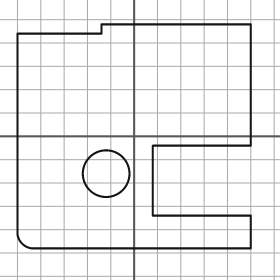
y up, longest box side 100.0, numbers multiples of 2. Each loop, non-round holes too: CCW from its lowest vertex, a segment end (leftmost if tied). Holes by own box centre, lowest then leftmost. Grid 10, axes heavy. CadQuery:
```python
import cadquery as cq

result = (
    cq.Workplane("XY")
    .moveTo(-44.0, -48.0)
    .lineTo(50.0, -48.0)
    .lineTo(50.0, -34.0)
    .lineTo(8.0, -34.0)
    .lineTo(8.0, -4.0)
    .lineTo(50.0, -4.0)
    .lineTo(50.0, 48.0)
    .lineTo(-14.0, 48.0)
    .lineTo(-14.0, 44.0)
    .lineTo(-50.0, 44.0)
    .lineTo(-50.0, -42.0)
    .threePointArc((-48.0, -46.0), (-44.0, -48.0))
    .close()
    .moveTo(-12.0, -16.0)
    .circle(10.0)
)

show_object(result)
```